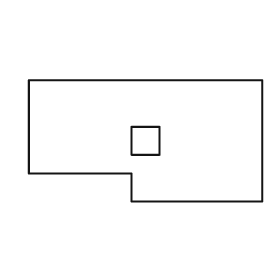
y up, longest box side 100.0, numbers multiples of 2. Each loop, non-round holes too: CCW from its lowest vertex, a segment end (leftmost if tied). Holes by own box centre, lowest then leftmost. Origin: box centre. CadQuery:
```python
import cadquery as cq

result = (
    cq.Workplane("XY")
    .moveTo(-6.0, -26.0)
    .lineTo(50.0, -26.0)
    .lineTo(50.0, 26.0)
    .lineTo(-50.0, 26.0)
    .lineTo(-50.0, -14.0)
    .lineTo(-6.0, -14.0)
    .close()
    .moveTo(-6.0, -6.0)
    .lineTo(6.0, -6.0)
    .lineTo(6.0, 6.0)
    .lineTo(-6.0, 6.0)
    .close()
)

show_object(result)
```